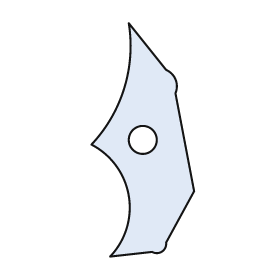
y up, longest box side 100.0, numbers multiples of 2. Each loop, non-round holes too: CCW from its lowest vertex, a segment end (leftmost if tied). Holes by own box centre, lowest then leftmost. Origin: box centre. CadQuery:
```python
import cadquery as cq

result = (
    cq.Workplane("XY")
    .moveTo(-14.0, -50.0)
    .lineTo(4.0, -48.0)
    .threePointArc((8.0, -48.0), (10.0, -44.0))
    .lineTo(22.0, -22.0)
    .lineTo(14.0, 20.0)
    .threePointArc((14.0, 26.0), (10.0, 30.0))
    .lineTo(-6.0, 50.0)
    .threePointArc((-8.0, 22.0), (-22.0, -2.0))
    .threePointArc((-6.0, -24.0), (-14.0, -50.0))
    .close()
    .moveTo(0.0, 0.0)
    .circle(6.0)
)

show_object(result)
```